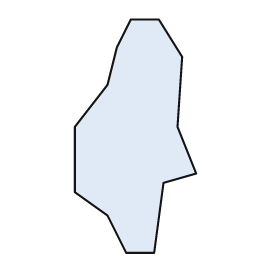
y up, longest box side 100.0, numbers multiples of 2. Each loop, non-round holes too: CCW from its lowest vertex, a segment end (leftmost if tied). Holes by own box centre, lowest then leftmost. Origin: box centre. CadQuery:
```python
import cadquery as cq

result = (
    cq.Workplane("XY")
    .moveTo(-4.0, -50.0)
    .lineTo(8.0, -50.0)
    .lineTo(12.0, -20.0)
    .lineTo(26.0, -16.0)
    .lineTo(18.0, 4.0)
    .lineTo(20.0, 34.0)
    .lineTo(10.0, 50.0)
    .lineTo(-2.0, 50.0)
    .lineTo(-8.0, 38.0)
    .lineTo(-12.0, 22.0)
    .lineTo(-26.0, 4.0)
    .lineTo(-26.0, -24.0)
    .lineTo(-12.0, -34.0)
    .close()
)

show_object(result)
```